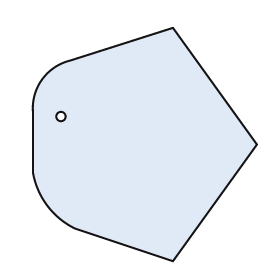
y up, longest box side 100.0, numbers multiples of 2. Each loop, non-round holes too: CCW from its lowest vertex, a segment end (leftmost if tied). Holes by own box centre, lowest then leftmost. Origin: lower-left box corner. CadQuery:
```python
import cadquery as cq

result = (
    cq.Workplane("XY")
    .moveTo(60.0, 0.0)
    .lineTo(96.0, 50.0)
    .lineTo(60.0, 100.0)
    .lineTo(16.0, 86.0)
    .threePointArc((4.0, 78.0), (0.0, 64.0))
    .lineTo(0.0, 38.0)
    .threePointArc((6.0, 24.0), (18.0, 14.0))
    .close()
    .moveTo(12.0, 62.0)
    .circle(2.0)
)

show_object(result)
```